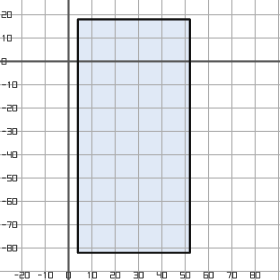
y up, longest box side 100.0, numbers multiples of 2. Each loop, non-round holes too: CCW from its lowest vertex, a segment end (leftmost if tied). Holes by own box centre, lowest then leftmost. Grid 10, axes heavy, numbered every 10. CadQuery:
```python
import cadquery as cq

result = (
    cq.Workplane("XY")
    .moveTo(4.0, -82.0)
    .lineTo(52.0, -82.0)
    .lineTo(52.0, 18.0)
    .lineTo(4.0, 18.0)
    .close()
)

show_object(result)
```